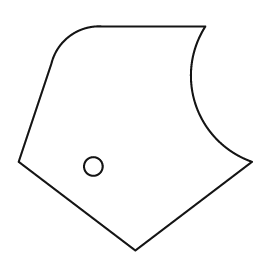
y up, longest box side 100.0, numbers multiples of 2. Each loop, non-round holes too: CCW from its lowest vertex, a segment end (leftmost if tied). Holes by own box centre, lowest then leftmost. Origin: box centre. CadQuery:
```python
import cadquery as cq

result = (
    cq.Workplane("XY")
    .moveTo(0.0, -48.0)
    .lineTo(50.0, -10.0)
    .threePointArc((26.0, 14.0), (30.0, 48.0))
    .lineTo(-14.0, 48.0)
    .threePointArc((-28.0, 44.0), (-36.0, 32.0))
    .lineTo(-50.0, -10.0)
    .close()
    .moveTo(-18.0, -12.0)
    .circle(4.0)
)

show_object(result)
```